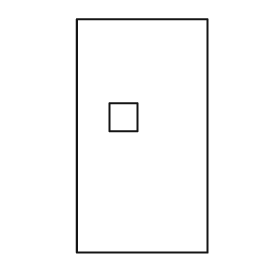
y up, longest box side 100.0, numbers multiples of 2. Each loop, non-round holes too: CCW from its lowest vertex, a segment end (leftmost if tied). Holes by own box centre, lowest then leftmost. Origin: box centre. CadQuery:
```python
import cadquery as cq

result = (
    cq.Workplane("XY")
    .moveTo(-28.0, -50.0)
    .lineTo(28.0, -50.0)
    .lineTo(28.0, 50.0)
    .lineTo(-28.0, 50.0)
    .close()
    .moveTo(-14.0, 2.0)
    .lineTo(-2.0, 2.0)
    .lineTo(-2.0, 14.0)
    .lineTo(-14.0, 14.0)
    .close()
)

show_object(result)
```